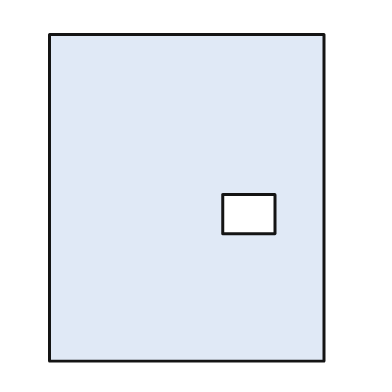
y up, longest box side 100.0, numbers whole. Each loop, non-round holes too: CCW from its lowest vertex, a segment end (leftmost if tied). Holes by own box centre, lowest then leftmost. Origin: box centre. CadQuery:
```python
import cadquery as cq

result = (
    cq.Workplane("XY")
    .moveTo(-42.0, -50.0)
    .lineTo(42.0, -50.0)
    .lineTo(42.0, 50.0)
    .lineTo(-42.0, 50.0)
    .close()
    .moveTo(11.0, -11.0)
    .lineTo(27.0, -11.0)
    .lineTo(27.0, 1.0)
    .lineTo(11.0, 1.0)
    .close()
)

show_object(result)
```